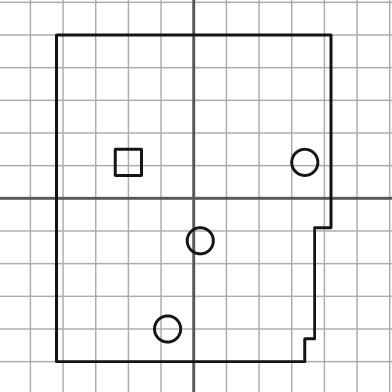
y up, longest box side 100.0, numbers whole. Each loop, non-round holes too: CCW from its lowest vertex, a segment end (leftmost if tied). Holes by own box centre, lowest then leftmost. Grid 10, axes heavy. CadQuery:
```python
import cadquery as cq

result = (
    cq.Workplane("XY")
    .moveTo(-42.0, -50.0)
    .lineTo(34.0, -50.0)
    .lineTo(34.0, -43.0)
    .lineTo(37.0, -43.0)
    .lineTo(37.0, -9.0)
    .lineTo(42.0, -9.0)
    .lineTo(42.0, 50.0)
    .lineTo(-42.0, 50.0)
    .close()
    .moveTo(-8.0, -40.0)
    .circle(4.0)
    .moveTo(2.0, -13.0)
    .circle(4.0)
    .moveTo(-24.0, 7.0)
    .lineTo(-16.0, 7.0)
    .lineTo(-16.0, 15.0)
    .lineTo(-24.0, 15.0)
    .close()
    .moveTo(34.0, 11.0)
    .circle(4.0)
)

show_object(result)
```